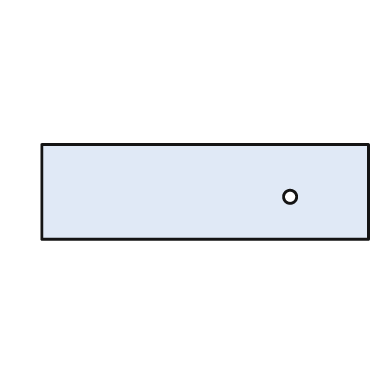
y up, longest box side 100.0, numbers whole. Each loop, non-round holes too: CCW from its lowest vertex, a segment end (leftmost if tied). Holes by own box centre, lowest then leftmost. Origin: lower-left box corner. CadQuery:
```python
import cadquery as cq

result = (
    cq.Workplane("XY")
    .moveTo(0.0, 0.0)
    .lineTo(100.0, 0.0)
    .lineTo(100.0, 29.0)
    .lineTo(0.0, 29.0)
    .close()
    .moveTo(76.0, 13.0)
    .circle(2.0)
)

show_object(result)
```